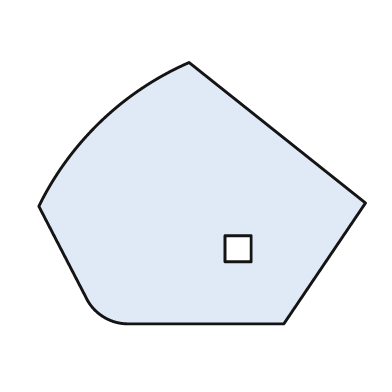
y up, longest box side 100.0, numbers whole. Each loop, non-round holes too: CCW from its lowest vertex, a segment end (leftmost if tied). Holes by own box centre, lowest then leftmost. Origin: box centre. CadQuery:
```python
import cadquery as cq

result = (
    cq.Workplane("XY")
    .moveTo(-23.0, -40.0)
    .lineTo(25.0, -40.0)
    .lineTo(50.0, -3.0)
    .lineTo(-4.0, 40.0)
    .threePointArc((-31.0, 22.0), (-50.0, -4.0))
    .lineTo(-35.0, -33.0)
    .threePointArc((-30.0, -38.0), (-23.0, -40.0))
    .close()
    .moveTo(7.0, -21.0)
    .lineTo(15.0, -21.0)
    .lineTo(15.0, -13.0)
    .lineTo(7.0, -13.0)
    .close()
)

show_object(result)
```